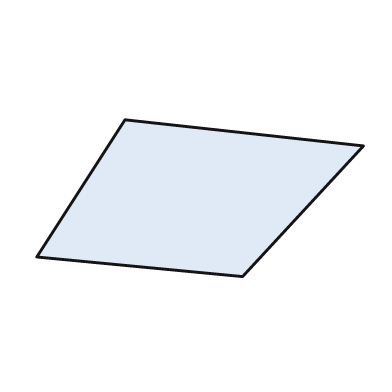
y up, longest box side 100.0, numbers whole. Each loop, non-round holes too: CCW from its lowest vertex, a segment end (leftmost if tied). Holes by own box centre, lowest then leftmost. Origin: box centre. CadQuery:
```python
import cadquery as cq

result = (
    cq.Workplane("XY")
    .moveTo(13.0, -24.0)
    .lineTo(50.0, 16.0)
    .lineTo(-23.0, 24.0)
    .lineTo(-50.0, -18.0)
    .close()
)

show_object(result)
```